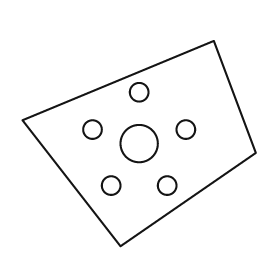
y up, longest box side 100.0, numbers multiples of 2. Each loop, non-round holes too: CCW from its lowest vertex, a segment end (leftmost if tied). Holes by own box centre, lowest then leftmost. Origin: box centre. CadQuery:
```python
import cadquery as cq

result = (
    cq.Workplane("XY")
    .moveTo(-8.0, -44.0)
    .lineTo(50.0, -4.0)
    .lineTo(32.0, 44.0)
    .lineTo(-50.0, 10.0)
    .close()
    .moveTo(-12.0, -18.0)
    .circle(4.0)
    .moveTo(12.0, -18.0)
    .circle(4.0)
    .moveTo(0.0, 0.0)
    .circle(8.0)
    .moveTo(-20.0, 6.0)
    .circle(4.0)
    .moveTo(20.0, 6.0)
    .circle(4.0)
    .moveTo(0.0, 22.0)
    .circle(4.0)
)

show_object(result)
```